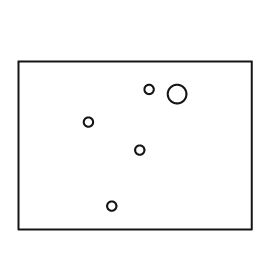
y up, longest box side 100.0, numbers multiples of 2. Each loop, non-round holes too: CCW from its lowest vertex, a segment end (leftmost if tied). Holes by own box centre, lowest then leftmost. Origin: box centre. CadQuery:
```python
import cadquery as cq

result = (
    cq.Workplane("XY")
    .moveTo(-50.0, -36.0)
    .lineTo(50.0, -36.0)
    .lineTo(50.0, 36.0)
    .lineTo(-50.0, 36.0)
    .close()
    .moveTo(-10.0, -26.0)
    .circle(2.0)
    .moveTo(2.0, -2.0)
    .circle(2.0)
    .moveTo(-20.0, 10.0)
    .circle(2.0)
    .moveTo(18.0, 22.0)
    .circle(4.0)
    .moveTo(6.0, 24.0)
    .circle(2.0)
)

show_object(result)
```